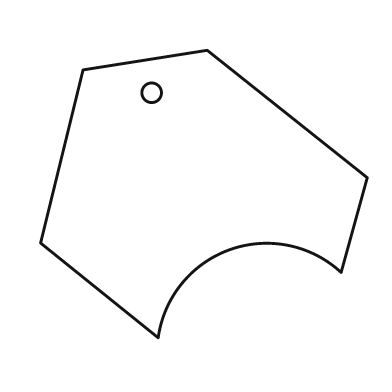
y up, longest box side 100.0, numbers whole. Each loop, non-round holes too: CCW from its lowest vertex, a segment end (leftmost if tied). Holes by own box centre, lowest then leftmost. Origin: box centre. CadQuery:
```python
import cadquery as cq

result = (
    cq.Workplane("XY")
    .moveTo(-14.0, -44.0)
    .threePointArc((8.0, -17.0), (42.0, -24.0))
    .lineTo(50.0, 5.0)
    .lineTo(1.0, 44.0)
    .lineTo(-37.0, 38.0)
    .lineTo(-50.0, -15.0)
    .close()
    .moveTo(-16.0, 31.0)
    .circle(3.0)
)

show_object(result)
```